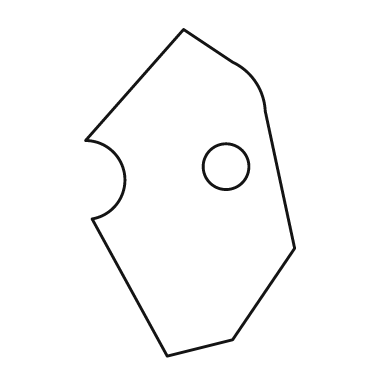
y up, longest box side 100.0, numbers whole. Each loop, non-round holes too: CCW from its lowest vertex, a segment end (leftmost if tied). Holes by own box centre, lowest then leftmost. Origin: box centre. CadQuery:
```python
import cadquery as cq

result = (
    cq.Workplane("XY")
    .moveTo(-7.0, -50.0)
    .lineTo(13.0, -45.0)
    .lineTo(32.0, -17.0)
    .lineTo(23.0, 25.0)
    .threePointArc((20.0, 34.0), (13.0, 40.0))
    .lineTo(-2.0, 50.0)
    .lineTo(-32.0, 16.0)
    .threePointArc((-20.0, 5.0), (-30.0, -8.0))
    .close()
    .moveTo(11.0, 8.0)
    .circle(7.0)
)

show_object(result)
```